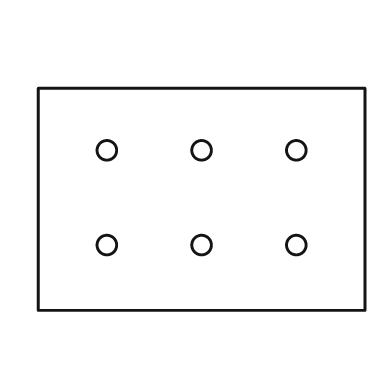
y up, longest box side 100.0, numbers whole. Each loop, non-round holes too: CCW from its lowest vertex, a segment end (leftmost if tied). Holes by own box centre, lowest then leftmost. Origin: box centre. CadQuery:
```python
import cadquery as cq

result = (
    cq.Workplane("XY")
    .moveTo(-50.0, -34.0)
    .lineTo(50.0, -34.0)
    .lineTo(50.0, 34.0)
    .lineTo(-50.0, 34.0)
    .close()
    .moveTo(-29.0, -14.0)
    .circle(3.0)
    .moveTo(0.0, -14.0)
    .circle(3.0)
    .moveTo(29.0, -14.0)
    .circle(3.0)
    .moveTo(-29.0, 15.0)
    .circle(3.0)
    .moveTo(0.0, 15.0)
    .circle(3.0)
    .moveTo(29.0, 15.0)
    .circle(3.0)
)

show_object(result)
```